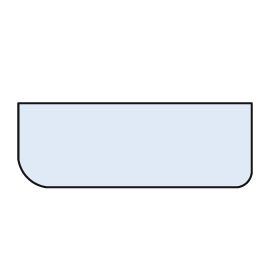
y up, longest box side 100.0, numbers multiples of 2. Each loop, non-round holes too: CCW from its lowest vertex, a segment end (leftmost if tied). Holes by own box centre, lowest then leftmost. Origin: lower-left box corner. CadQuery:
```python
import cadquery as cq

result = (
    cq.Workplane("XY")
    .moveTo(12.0, 0.0)
    .lineTo(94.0, 0.0)
    .threePointArc((98.0, 2.0), (100.0, 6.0))
    .lineTo(100.0, 36.0)
    .lineTo(0.0, 36.0)
    .lineTo(0.0, 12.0)
    .threePointArc((4.0, 4.0), (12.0, 0.0))
    .close()
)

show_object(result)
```